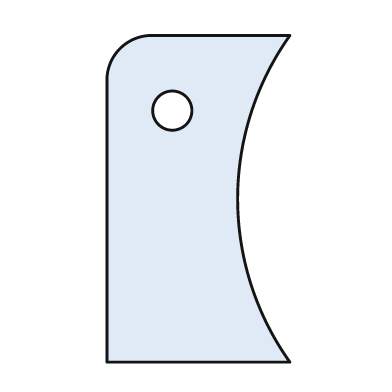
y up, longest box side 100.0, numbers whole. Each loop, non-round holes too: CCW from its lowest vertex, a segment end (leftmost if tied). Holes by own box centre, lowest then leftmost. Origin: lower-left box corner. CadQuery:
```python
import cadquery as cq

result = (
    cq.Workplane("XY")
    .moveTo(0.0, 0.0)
    .lineTo(56.0, 0.0)
    .threePointArc((40.0, 50.0), (56.0, 100.0))
    .lineTo(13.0, 100.0)
    .threePointArc((4.0, 96.0), (0.0, 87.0))
    .close()
    .moveTo(20.0, 77.0)
    .circle(6.0)
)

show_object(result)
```